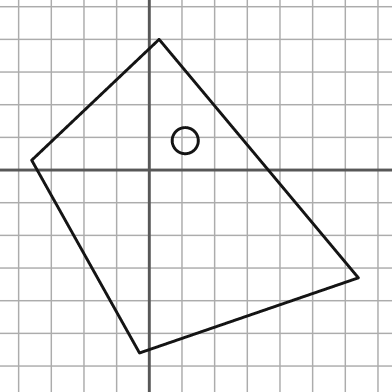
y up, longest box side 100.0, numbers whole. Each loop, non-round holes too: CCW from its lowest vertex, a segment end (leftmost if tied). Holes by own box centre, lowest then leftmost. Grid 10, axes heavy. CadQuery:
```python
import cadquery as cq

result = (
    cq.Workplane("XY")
    .moveTo(-3.0, -56.0)
    .lineTo(64.0, -33.0)
    .lineTo(3.0, 40.0)
    .lineTo(-36.0, 3.0)
    .close()
    .moveTo(11.0, 9.0)
    .circle(4.0)
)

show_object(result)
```